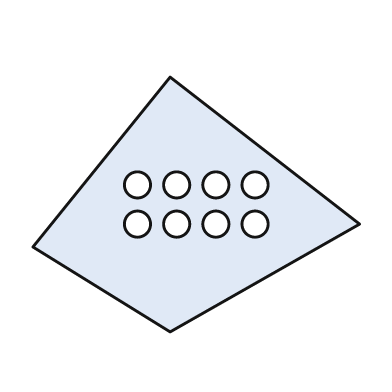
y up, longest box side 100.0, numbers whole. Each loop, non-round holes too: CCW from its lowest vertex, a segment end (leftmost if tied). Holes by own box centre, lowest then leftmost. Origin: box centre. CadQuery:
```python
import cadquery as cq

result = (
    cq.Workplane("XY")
    .moveTo(-8.0, -39.0)
    .lineTo(50.0, -6.0)
    .lineTo(-8.0, 39.0)
    .lineTo(-50.0, -13.0)
    .close()
    .moveTo(-18.0, -6.0)
    .circle(4.0)
    .moveTo(-6.0, -6.0)
    .circle(4.0)
    .moveTo(6.0, -6.0)
    .circle(4.0)
    .moveTo(18.0, -6.0)
    .circle(4.0)
    .moveTo(-18.0, 6.0)
    .circle(4.0)
    .moveTo(-6.0, 6.0)
    .circle(4.0)
    .moveTo(6.0, 6.0)
    .circle(4.0)
    .moveTo(18.0, 6.0)
    .circle(4.0)
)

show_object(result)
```